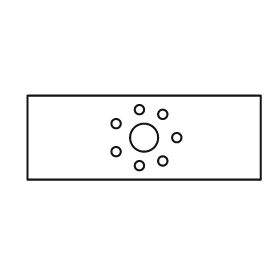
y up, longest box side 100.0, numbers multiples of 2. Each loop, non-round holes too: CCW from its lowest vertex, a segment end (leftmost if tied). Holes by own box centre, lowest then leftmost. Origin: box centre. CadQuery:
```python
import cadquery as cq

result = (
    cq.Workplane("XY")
    .moveTo(-50.0, -18.0)
    .lineTo(50.0, -18.0)
    .lineTo(50.0, 18.0)
    .lineTo(-50.0, 18.0)
    .close()
    .moveTo(-2.0, -12.0)
    .circle(2.0)
    .moveTo(8.0, -10.0)
    .circle(2.0)
    .moveTo(-12.0, -6.0)
    .circle(2.0)
    .moveTo(0.0, 0.0)
    .circle(6.0)
    .moveTo(14.0, 0.0)
    .circle(2.0)
    .moveTo(-12.0, 6.0)
    .circle(2.0)
    .moveTo(8.0, 10.0)
    .circle(2.0)
    .moveTo(-2.0, 12.0)
    .circle(2.0)
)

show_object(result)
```